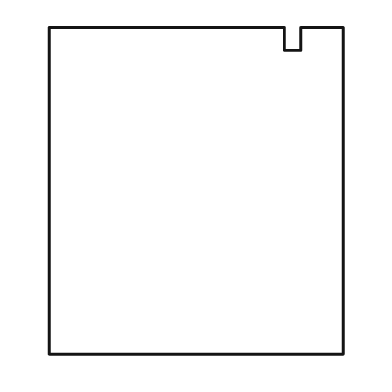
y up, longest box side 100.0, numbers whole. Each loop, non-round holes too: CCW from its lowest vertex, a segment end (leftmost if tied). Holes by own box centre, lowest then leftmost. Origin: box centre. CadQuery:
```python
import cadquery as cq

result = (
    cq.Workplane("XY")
    .moveTo(-45.0, -50.0)
    .lineTo(45.0, -50.0)
    .lineTo(45.0, 50.0)
    .lineTo(32.0, 50.0)
    .lineTo(32.0, 43.0)
    .lineTo(27.0, 43.0)
    .lineTo(27.0, 50.0)
    .lineTo(-45.0, 50.0)
    .close()
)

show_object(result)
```